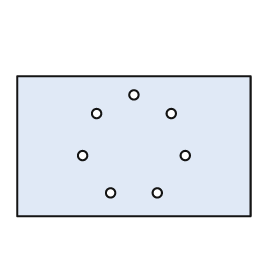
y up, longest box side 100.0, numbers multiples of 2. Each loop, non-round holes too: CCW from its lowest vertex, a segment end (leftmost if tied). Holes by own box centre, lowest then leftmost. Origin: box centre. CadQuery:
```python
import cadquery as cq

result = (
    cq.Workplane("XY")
    .moveTo(-50.0, -30.0)
    .lineTo(50.0, -30.0)
    .lineTo(50.0, 30.0)
    .lineTo(-50.0, 30.0)
    .close()
    .moveTo(-10.0, -20.0)
    .circle(2.0)
    .moveTo(10.0, -20.0)
    .circle(2.0)
    .moveTo(-22.0, -4.0)
    .circle(2.0)
    .moveTo(22.0, -4.0)
    .circle(2.0)
    .moveTo(-16.0, 14.0)
    .circle(2.0)
    .moveTo(16.0, 14.0)
    .circle(2.0)
    .moveTo(0.0, 22.0)
    .circle(2.0)
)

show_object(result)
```